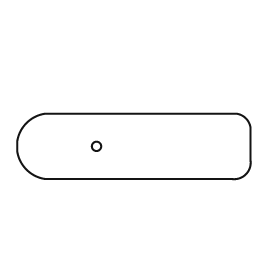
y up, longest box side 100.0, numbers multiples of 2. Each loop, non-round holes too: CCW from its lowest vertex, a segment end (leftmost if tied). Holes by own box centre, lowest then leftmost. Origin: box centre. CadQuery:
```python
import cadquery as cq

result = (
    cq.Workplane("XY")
    .moveTo(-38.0, -14.0)
    .lineTo(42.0, -14.0)
    .threePointArc((48.0, -12.0), (50.0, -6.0))
    .lineTo(50.0, 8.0)
    .threePointArc((48.0, 12.0), (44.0, 14.0))
    .lineTo(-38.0, 14.0)
    .threePointArc((-46.0, 10.0), (-50.0, 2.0))
    .lineTo(-50.0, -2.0)
    .threePointArc((-46.0, -10.0), (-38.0, -14.0))
    .close()
    .moveTo(-16.0, 0.0)
    .circle(2.0)
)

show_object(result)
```